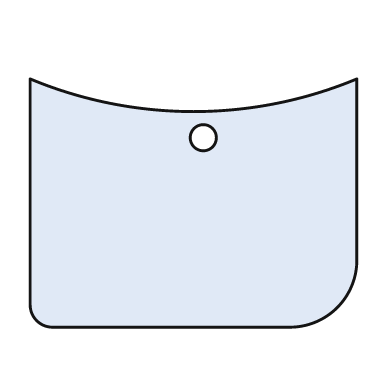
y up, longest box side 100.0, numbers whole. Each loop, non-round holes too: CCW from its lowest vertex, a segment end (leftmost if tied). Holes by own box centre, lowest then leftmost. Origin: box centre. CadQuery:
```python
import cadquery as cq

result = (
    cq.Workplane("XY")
    .moveTo(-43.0, -38.0)
    .lineTo(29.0, -38.0)
    .threePointArc((44.0, -32.0), (50.0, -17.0))
    .lineTo(50.0, 38.0)
    .threePointArc((0.0, 28.0), (-50.0, 38.0))
    .lineTo(-50.0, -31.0)
    .threePointArc((-48.0, -36.0), (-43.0, -38.0))
    .close()
    .moveTo(3.0, 20.0)
    .circle(4.0)
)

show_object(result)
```